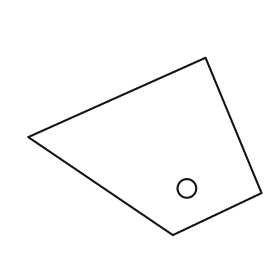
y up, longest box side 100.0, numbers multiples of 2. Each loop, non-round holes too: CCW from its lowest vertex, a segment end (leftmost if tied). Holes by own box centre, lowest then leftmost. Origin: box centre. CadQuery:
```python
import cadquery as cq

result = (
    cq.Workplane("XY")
    .moveTo(12.0, -38.0)
    .lineTo(50.0, -20.0)
    .lineTo(26.0, 38.0)
    .lineTo(-50.0, 4.0)
    .close()
    .moveTo(18.0, -18.0)
    .circle(4.0)
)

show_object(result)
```